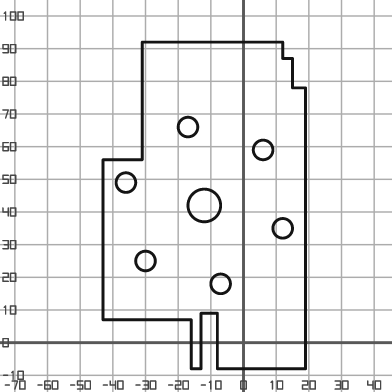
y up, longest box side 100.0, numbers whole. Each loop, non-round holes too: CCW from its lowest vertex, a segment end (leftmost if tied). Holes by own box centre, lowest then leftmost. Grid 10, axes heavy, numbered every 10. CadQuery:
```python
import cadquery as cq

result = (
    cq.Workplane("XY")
    .moveTo(-16.0, -8.0)
    .lineTo(-13.0, -8.0)
    .lineTo(-13.0, 9.0)
    .lineTo(-8.0, 9.0)
    .lineTo(-8.0, -8.0)
    .lineTo(19.0, -8.0)
    .lineTo(19.0, 78.0)
    .lineTo(15.0, 78.0)
    .lineTo(15.0, 87.0)
    .lineTo(12.0, 87.0)
    .lineTo(12.0, 92.0)
    .lineTo(-31.0, 92.0)
    .lineTo(-31.0, 56.0)
    .lineTo(-43.0, 56.0)
    .lineTo(-43.0, 7.0)
    .lineTo(-16.0, 7.0)
    .close()
    .moveTo(-7.0, 18.0)
    .circle(3.0)
    .moveTo(-30.0, 25.0)
    .circle(3.0)
    .moveTo(12.0, 35.0)
    .circle(3.0)
    .moveTo(-12.0, 42.0)
    .circle(5.0)
    .moveTo(-36.0, 49.0)
    .circle(3.0)
    .moveTo(6.0, 59.0)
    .circle(3.0)
    .moveTo(-17.0, 66.0)
    .circle(3.0)
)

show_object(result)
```